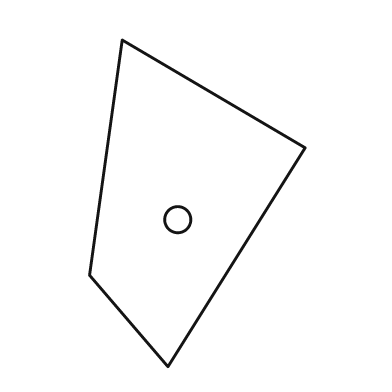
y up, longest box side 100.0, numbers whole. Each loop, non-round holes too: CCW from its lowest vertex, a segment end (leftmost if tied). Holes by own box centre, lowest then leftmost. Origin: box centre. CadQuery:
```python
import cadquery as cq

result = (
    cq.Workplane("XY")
    .moveTo(-9.0, -50.0)
    .lineTo(33.0, 17.0)
    .lineTo(-23.0, 50.0)
    .lineTo(-33.0, -22.0)
    .close()
    .moveTo(-6.0, -5.0)
    .circle(4.0)
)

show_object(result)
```